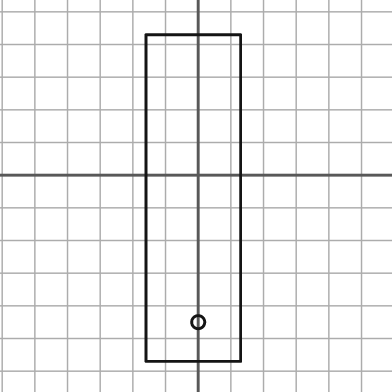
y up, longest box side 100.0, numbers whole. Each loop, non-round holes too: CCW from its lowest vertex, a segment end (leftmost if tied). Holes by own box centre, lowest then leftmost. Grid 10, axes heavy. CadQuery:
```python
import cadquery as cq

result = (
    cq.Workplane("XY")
    .moveTo(-16.0, -57.0)
    .lineTo(13.0, -57.0)
    .lineTo(13.0, 43.0)
    .lineTo(-16.0, 43.0)
    .close()
    .moveTo(0.0, -45.0)
    .circle(2.0)
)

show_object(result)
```